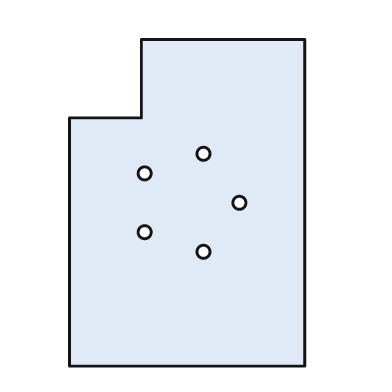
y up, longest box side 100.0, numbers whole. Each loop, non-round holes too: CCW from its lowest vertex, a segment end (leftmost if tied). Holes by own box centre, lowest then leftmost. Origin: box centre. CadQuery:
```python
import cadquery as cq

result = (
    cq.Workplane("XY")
    .moveTo(-36.0, -50.0)
    .lineTo(36.0, -50.0)
    .lineTo(36.0, 50.0)
    .lineTo(-14.0, 50.0)
    .lineTo(-14.0, 26.0)
    .lineTo(-36.0, 26.0)
    .close()
    .moveTo(5.0, -15.0)
    .circle(2.0)
    .moveTo(-13.0, -9.0)
    .circle(2.0)
    .moveTo(16.0, 0.0)
    .circle(2.0)
    .moveTo(-13.0, 9.0)
    .circle(2.0)
    .moveTo(5.0, 15.0)
    .circle(2.0)
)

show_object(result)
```